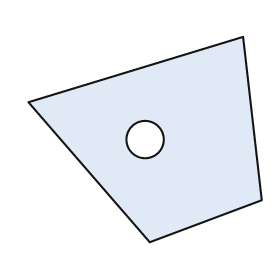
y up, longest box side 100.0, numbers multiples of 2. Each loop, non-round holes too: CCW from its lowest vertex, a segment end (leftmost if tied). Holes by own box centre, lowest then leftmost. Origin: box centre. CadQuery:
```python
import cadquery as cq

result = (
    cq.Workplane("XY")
    .moveTo(2.0, -44.0)
    .lineTo(50.0, -26.0)
    .lineTo(42.0, 44.0)
    .lineTo(-50.0, 16.0)
    .close()
    .moveTo(0.0, 0.0)
    .circle(8.0)
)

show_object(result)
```